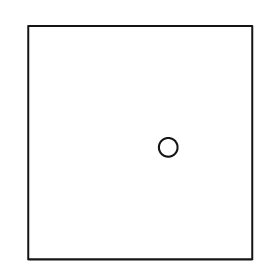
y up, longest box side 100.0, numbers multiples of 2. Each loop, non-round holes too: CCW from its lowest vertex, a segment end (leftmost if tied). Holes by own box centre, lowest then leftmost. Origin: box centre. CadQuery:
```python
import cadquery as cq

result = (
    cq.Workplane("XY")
    .moveTo(-48.0, -50.0)
    .lineTo(48.0, -50.0)
    .lineTo(48.0, 50.0)
    .lineTo(-48.0, 50.0)
    .close()
    .moveTo(12.0, -2.0)
    .circle(4.0)
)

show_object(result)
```